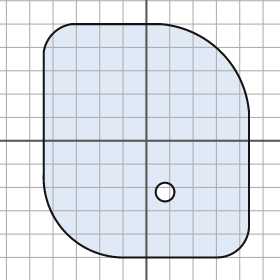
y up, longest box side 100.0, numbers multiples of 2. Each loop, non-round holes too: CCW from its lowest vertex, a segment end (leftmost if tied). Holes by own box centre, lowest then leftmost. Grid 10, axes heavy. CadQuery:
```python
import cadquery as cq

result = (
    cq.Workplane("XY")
    .moveTo(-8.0, -50.0)
    .lineTo(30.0, -50.0)
    .threePointArc((40.0, -46.0), (44.0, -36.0))
    .lineTo(44.0, 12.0)
    .threePointArc((32.0, 38.0), (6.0, 50.0))
    .lineTo(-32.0, 50.0)
    .threePointArc((-40.0, 46.0), (-44.0, 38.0))
    .lineTo(-44.0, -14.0)
    .threePointArc((-34.0, -40.0), (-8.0, -50.0))
    .close()
    .moveTo(8.0, -22.0)
    .circle(4.0)
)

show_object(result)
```